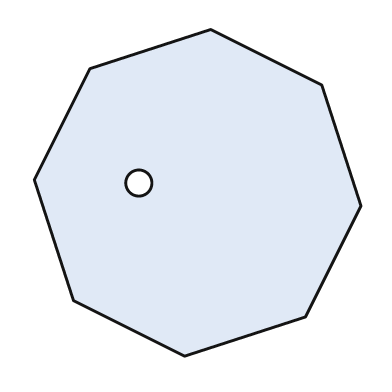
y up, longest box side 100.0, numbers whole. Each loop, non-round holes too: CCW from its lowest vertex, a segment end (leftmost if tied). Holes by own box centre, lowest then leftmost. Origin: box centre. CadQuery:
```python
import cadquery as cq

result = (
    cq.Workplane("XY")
    .moveTo(-4.0, -50.0)
    .lineTo(33.0, -38.0)
    .lineTo(50.0, -4.0)
    .lineTo(38.0, 33.0)
    .lineTo(4.0, 50.0)
    .lineTo(-33.0, 38.0)
    .lineTo(-50.0, 4.0)
    .lineTo(-38.0, -33.0)
    .close()
    .moveTo(-18.0, 3.0)
    .circle(4.0)
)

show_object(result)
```